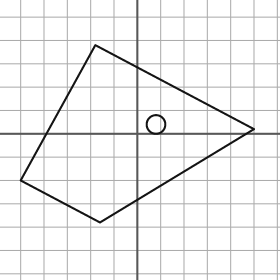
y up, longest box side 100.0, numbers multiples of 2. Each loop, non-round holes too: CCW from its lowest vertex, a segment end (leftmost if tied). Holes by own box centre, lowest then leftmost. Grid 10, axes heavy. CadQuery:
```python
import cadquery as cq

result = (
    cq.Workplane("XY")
    .moveTo(-16.0, -38.0)
    .lineTo(50.0, 2.0)
    .lineTo(-18.0, 38.0)
    .lineTo(-50.0, -20.0)
    .close()
    .moveTo(8.0, 4.0)
    .circle(4.0)
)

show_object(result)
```